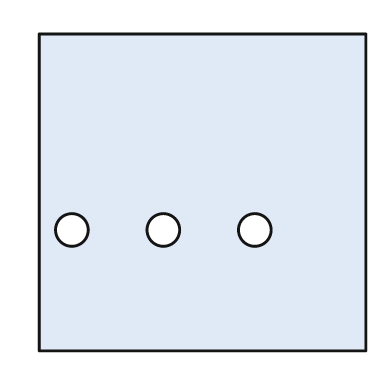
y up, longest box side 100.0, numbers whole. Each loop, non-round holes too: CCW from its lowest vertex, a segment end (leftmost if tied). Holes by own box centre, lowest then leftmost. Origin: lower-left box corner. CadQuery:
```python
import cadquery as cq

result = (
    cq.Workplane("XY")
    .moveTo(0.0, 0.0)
    .lineTo(100.0, 0.0)
    .lineTo(100.0, 97.0)
    .lineTo(0.0, 97.0)
    .close()
    .moveTo(10.0, 37.0)
    .circle(5.0)
    .moveTo(38.0, 37.0)
    .circle(5.0)
    .moveTo(66.0, 37.0)
    .circle(5.0)
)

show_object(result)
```